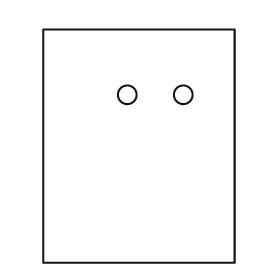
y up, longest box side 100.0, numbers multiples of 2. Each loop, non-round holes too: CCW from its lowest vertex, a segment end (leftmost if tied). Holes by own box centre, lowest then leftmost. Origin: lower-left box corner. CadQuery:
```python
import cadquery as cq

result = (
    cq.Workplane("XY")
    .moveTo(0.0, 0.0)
    .lineTo(82.0, 0.0)
    .lineTo(82.0, 100.0)
    .lineTo(0.0, 100.0)
    .close()
    .moveTo(36.0, 72.0)
    .circle(4.0)
    .moveTo(60.0, 72.0)
    .circle(4.0)
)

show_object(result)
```